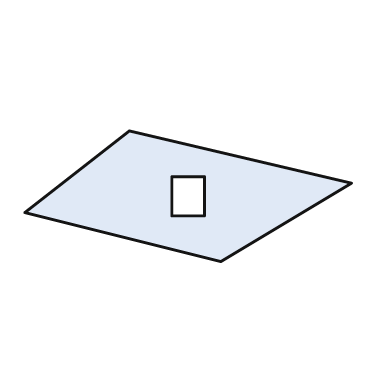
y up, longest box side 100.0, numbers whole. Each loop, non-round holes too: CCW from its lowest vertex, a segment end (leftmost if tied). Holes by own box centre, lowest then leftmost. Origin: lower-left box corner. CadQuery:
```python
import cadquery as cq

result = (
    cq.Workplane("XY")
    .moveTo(60.0, 0.0)
    .lineTo(100.0, 24.0)
    .lineTo(32.0, 40.0)
    .lineTo(0.0, 15.0)
    .close()
    .moveTo(45.0, 14.0)
    .lineTo(55.0, 14.0)
    .lineTo(55.0, 26.0)
    .lineTo(45.0, 26.0)
    .close()
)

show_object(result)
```